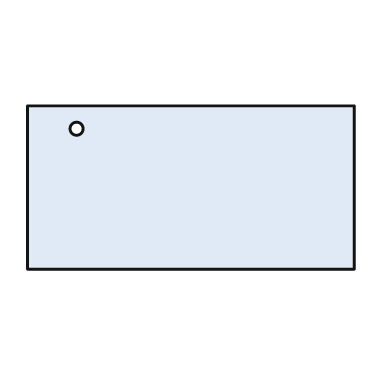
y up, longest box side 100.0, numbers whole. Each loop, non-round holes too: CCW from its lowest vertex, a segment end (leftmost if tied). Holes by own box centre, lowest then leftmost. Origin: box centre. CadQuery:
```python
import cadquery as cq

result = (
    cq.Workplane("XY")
    .moveTo(-50.0, -25.0)
    .lineTo(50.0, -25.0)
    .lineTo(50.0, 25.0)
    .lineTo(-50.0, 25.0)
    .close()
    .moveTo(-35.0, 18.0)
    .circle(2.0)
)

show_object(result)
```